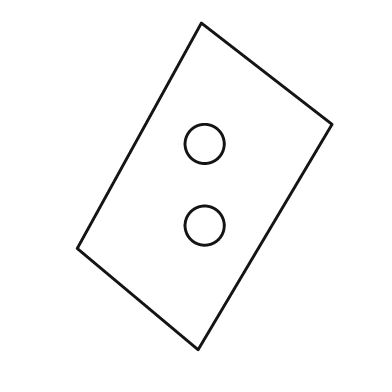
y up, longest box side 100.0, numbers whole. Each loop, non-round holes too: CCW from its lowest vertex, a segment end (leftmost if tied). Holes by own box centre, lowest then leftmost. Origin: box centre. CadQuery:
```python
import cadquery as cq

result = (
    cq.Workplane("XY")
    .moveTo(-2.0, -50.0)
    .lineTo(39.0, 19.0)
    .lineTo(-1.0, 50.0)
    .lineTo(-39.0, -19.0)
    .close()
    .moveTo(0.0, -12.0)
    .circle(6.0)
    .moveTo(0.0, 13.0)
    .circle(6.0)
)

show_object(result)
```